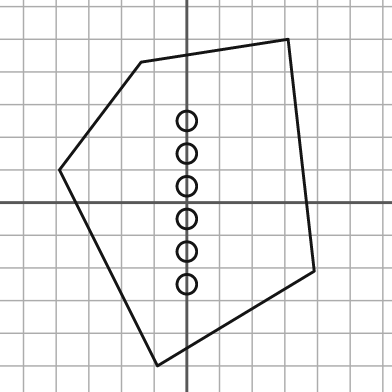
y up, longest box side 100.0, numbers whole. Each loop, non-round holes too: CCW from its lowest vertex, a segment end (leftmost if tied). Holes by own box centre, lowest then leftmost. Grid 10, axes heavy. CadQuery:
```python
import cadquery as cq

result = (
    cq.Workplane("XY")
    .moveTo(-9.0, -50.0)
    .lineTo(39.0, -21.0)
    .lineTo(31.0, 50.0)
    .lineTo(-14.0, 43.0)
    .lineTo(-39.0, 10.0)
    .close()
    .moveTo(0.0, -25.0)
    .circle(3.0)
    .moveTo(0.0, -15.0)
    .circle(3.0)
    .moveTo(0.0, -5.0)
    .circle(3.0)
    .moveTo(0.0, 5.0)
    .circle(3.0)
    .moveTo(0.0, 15.0)
    .circle(3.0)
    .moveTo(0.0, 25.0)
    .circle(3.0)
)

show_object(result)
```